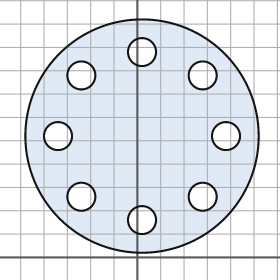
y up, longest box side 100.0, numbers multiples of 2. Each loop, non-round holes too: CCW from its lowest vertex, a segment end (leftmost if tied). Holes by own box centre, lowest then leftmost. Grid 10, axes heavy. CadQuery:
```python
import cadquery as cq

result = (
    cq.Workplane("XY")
    .moveTo(2.0, 52.0)
    .circle(50.0)
    .moveTo(2.0, 16.0)
    .circle(6.0)
    .moveTo(-24.0, 26.0)
    .circle(6.0)
    .moveTo(28.0, 26.0)
    .circle(6.0)
    .moveTo(-34.0, 52.0)
    .circle(6.0)
    .moveTo(38.0, 52.0)
    .circle(6.0)
    .moveTo(-24.0, 78.0)
    .circle(6.0)
    .moveTo(28.0, 78.0)
    .circle(6.0)
    .moveTo(2.0, 88.0)
    .circle(6.0)
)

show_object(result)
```